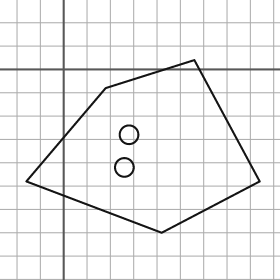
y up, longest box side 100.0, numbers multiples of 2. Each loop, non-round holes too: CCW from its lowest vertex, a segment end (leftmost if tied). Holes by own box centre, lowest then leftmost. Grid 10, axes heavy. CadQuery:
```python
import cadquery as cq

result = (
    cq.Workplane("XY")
    .moveTo(42.0, -70.0)
    .lineTo(84.0, -48.0)
    .lineTo(56.0, 4.0)
    .lineTo(18.0, -8.0)
    .lineTo(-16.0, -48.0)
    .close()
    .moveTo(26.0, -42.0)
    .circle(4.0)
    .moveTo(28.0, -28.0)
    .circle(4.0)
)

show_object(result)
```